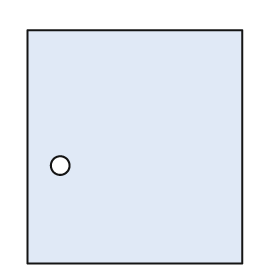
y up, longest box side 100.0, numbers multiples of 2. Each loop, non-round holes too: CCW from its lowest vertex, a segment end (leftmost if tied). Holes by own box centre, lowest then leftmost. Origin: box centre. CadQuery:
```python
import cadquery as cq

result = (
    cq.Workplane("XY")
    .moveTo(-46.0, -50.0)
    .lineTo(46.0, -50.0)
    .lineTo(46.0, 50.0)
    .lineTo(-46.0, 50.0)
    .close()
    .moveTo(-32.0, -8.0)
    .circle(4.0)
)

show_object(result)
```